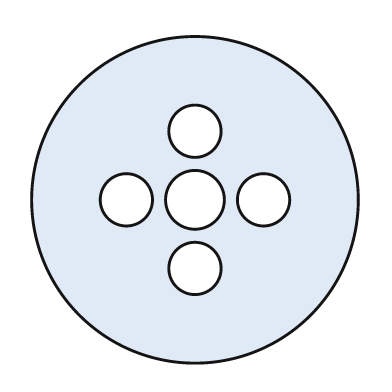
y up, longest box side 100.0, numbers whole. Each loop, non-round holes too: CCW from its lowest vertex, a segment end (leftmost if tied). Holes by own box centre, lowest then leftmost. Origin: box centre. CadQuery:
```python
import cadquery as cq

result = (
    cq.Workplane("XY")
    .moveTo(0.0, 0.0)
    .circle(50.0)
    .moveTo(0.0, -21.0)
    .circle(8.0)
    .moveTo(-21.0, 0.0)
    .circle(8.0)
    .moveTo(0.0, 0.0)
    .circle(9.0)
    .moveTo(21.0, 0.0)
    .circle(8.0)
    .moveTo(0.0, 21.0)
    .circle(8.0)
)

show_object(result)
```